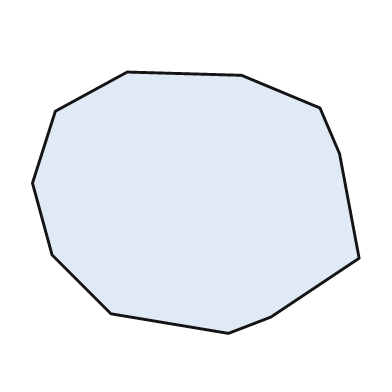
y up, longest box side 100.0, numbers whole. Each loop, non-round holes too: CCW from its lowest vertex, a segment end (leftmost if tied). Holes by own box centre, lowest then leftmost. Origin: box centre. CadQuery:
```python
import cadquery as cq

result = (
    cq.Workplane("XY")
    .moveTo(10.0, -40.0)
    .lineTo(23.0, -35.0)
    .lineTo(50.0, -17.0)
    .lineTo(44.0, 15.0)
    .lineTo(38.0, 29.0)
    .lineTo(14.0, 39.0)
    .lineTo(-21.0, 40.0)
    .lineTo(-43.0, 28.0)
    .lineTo(-50.0, 6.0)
    .lineTo(-44.0, -16.0)
    .lineTo(-26.0, -34.0)
    .close()
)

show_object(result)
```